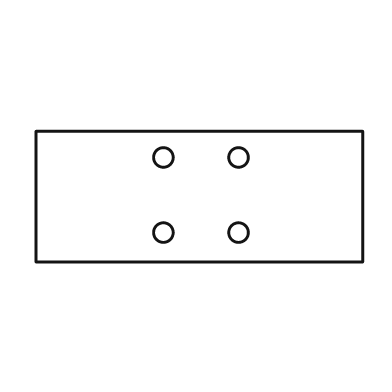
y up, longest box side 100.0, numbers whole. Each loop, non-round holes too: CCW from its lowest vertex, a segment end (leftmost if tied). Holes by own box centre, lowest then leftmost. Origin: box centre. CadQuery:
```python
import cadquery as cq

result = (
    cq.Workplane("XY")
    .moveTo(-50.0, -20.0)
    .lineTo(50.0, -20.0)
    .lineTo(50.0, 20.0)
    .lineTo(-50.0, 20.0)
    .close()
    .moveTo(-11.0, -11.0)
    .circle(3.0)
    .moveTo(12.0, -11.0)
    .circle(3.0)
    .moveTo(-11.0, 12.0)
    .circle(3.0)
    .moveTo(12.0, 12.0)
    .circle(3.0)
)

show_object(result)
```